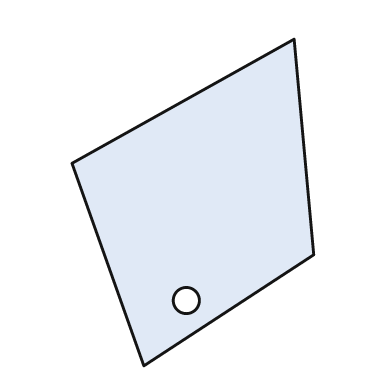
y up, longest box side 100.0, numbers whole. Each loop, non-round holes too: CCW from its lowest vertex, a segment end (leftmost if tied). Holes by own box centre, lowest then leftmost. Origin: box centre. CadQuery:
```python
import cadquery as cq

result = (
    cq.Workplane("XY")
    .moveTo(-15.0, -50.0)
    .lineTo(37.0, -16.0)
    .lineTo(31.0, 50.0)
    .lineTo(-37.0, 12.0)
    .close()
    .moveTo(-2.0, -30.0)
    .circle(4.0)
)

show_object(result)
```